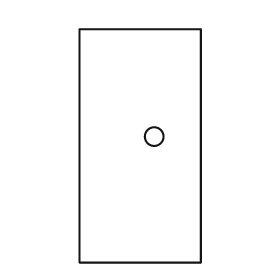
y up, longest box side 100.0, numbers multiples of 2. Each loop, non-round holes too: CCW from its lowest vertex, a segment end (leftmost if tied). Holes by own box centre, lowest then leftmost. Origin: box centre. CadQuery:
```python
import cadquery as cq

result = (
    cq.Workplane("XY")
    .moveTo(-26.0, -50.0)
    .lineTo(26.0, -50.0)
    .lineTo(26.0, 50.0)
    .lineTo(-26.0, 50.0)
    .close()
    .moveTo(6.0, 4.0)
    .circle(4.0)
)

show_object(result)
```